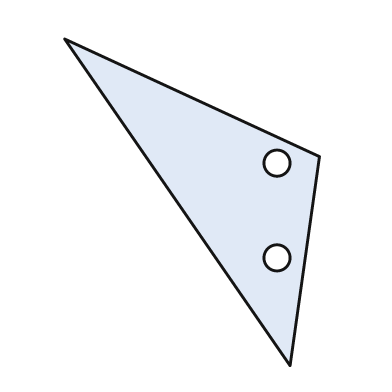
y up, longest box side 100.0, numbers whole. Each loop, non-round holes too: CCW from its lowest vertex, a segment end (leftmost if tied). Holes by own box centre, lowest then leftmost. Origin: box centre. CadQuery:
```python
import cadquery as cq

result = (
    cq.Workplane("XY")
    .moveTo(30.0, -50.0)
    .lineTo(39.0, 14.0)
    .lineTo(-39.0, 50.0)
    .close()
    .moveTo(26.0, -17.0)
    .circle(4.0)
    .moveTo(26.0, 12.0)
    .circle(4.0)
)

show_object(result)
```